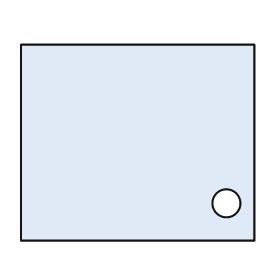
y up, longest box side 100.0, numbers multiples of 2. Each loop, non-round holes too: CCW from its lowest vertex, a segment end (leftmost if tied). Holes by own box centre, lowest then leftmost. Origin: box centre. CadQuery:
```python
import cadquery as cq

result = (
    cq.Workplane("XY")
    .moveTo(-50.0, -42.0)
    .lineTo(50.0, -42.0)
    .lineTo(50.0, 42.0)
    .lineTo(-50.0, 42.0)
    .close()
    .moveTo(38.0, -26.0)
    .circle(6.0)
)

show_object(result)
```